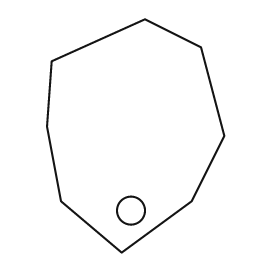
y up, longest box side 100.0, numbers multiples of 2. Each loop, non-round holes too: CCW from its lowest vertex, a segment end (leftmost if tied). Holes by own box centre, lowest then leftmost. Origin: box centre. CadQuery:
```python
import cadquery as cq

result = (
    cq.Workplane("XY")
    .moveTo(-6.0, -50.0)
    .lineTo(24.0, -28.0)
    .lineTo(38.0, 0.0)
    .lineTo(28.0, 38.0)
    .lineTo(4.0, 50.0)
    .lineTo(-36.0, 32.0)
    .lineTo(-38.0, 4.0)
    .lineTo(-32.0, -28.0)
    .close()
    .moveTo(-2.0, -32.0)
    .circle(6.0)
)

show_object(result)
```